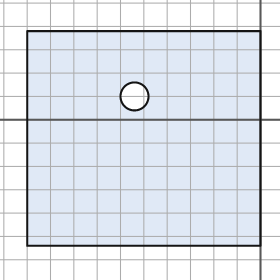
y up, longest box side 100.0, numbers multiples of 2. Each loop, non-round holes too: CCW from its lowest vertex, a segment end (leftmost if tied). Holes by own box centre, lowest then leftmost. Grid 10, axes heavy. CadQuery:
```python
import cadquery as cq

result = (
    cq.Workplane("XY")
    .moveTo(-100.0, -54.0)
    .lineTo(0.0, -54.0)
    .lineTo(0.0, 38.0)
    .lineTo(-100.0, 38.0)
    .close()
    .moveTo(-54.0, 10.0)
    .circle(6.0)
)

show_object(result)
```